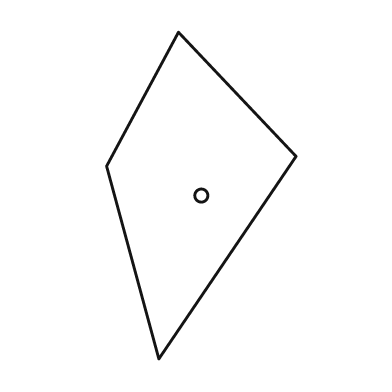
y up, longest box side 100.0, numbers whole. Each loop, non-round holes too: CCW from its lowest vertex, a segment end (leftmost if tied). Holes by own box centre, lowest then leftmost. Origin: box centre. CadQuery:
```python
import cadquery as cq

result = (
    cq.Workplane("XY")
    .moveTo(-13.0, -50.0)
    .lineTo(29.0, 12.0)
    .lineTo(-7.0, 50.0)
    .lineTo(-29.0, 9.0)
    .close()
    .moveTo(0.0, 0.0)
    .circle(2.0)
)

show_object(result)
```